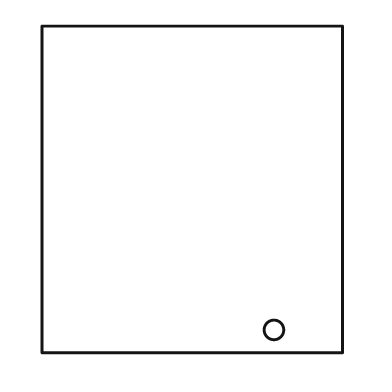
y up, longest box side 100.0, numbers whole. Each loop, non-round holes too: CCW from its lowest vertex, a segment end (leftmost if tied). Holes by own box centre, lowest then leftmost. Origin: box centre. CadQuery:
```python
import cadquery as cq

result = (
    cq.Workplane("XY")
    .moveTo(-46.0, -50.0)
    .lineTo(46.0, -50.0)
    .lineTo(46.0, 50.0)
    .lineTo(-46.0, 50.0)
    .close()
    .moveTo(25.0, -43.0)
    .circle(3.0)
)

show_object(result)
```